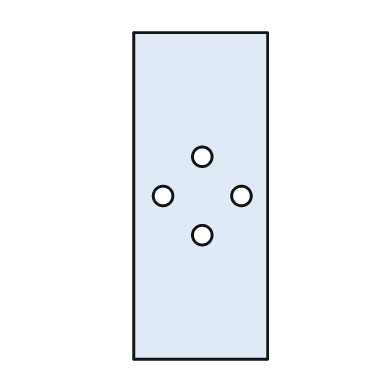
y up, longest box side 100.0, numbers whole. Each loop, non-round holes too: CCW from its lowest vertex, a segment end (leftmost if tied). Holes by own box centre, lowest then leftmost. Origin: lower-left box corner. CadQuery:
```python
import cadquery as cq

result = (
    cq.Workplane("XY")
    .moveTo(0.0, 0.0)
    .lineTo(41.0, 0.0)
    .lineTo(41.0, 100.0)
    .lineTo(0.0, 100.0)
    .close()
    .moveTo(21.0, 38.0)
    .circle(3.0)
    .moveTo(9.0, 50.0)
    .circle(3.0)
    .moveTo(33.0, 50.0)
    .circle(3.0)
    .moveTo(21.0, 62.0)
    .circle(3.0)
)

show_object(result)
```